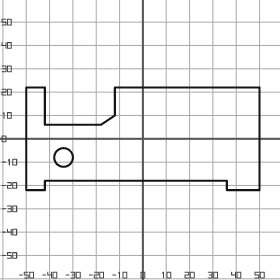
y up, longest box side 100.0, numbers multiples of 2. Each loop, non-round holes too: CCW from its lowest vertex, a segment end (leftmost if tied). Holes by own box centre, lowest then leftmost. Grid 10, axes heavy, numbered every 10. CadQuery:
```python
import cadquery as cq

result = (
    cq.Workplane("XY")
    .moveTo(-50.0, -22.0)
    .lineTo(-42.0, -22.0)
    .lineTo(-42.0, -18.0)
    .lineTo(36.0, -18.0)
    .lineTo(36.0, -22.0)
    .lineTo(50.0, -22.0)
    .lineTo(50.0, 22.0)
    .lineTo(-12.0, 22.0)
    .lineTo(-12.0, 10.0)
    .lineTo(-18.0, 6.0)
    .lineTo(-42.0, 6.0)
    .lineTo(-42.0, 22.0)
    .lineTo(-50.0, 22.0)
    .close()
    .moveTo(-34.0, -8.0)
    .circle(4.0)
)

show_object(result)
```